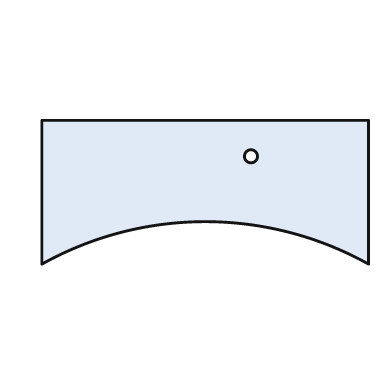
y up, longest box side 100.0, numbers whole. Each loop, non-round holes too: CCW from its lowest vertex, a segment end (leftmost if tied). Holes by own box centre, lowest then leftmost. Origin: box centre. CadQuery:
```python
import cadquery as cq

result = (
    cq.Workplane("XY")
    .moveTo(-50.0, -22.0)
    .threePointArc((0.0, -9.0), (50.0, -22.0))
    .lineTo(50.0, 22.0)
    .lineTo(-50.0, 22.0)
    .close()
    .moveTo(14.0, 11.0)
    .circle(2.0)
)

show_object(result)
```